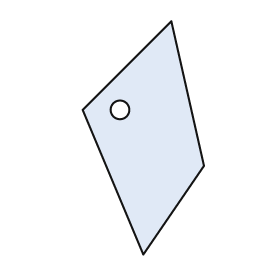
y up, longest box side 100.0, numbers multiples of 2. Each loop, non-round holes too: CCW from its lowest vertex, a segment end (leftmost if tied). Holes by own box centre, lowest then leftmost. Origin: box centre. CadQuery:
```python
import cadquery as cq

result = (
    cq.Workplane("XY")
    .moveTo(0.0, -50.0)
    .lineTo(26.0, -12.0)
    .lineTo(12.0, 50.0)
    .lineTo(-26.0, 12.0)
    .close()
    .moveTo(-10.0, 12.0)
    .circle(4.0)
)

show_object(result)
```